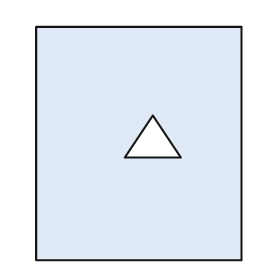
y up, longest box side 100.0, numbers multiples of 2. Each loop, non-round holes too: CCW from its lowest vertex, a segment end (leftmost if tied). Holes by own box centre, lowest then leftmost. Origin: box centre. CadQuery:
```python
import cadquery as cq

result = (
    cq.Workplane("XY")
    .moveTo(-44.0, -50.0)
    .lineTo(44.0, -50.0)
    .lineTo(44.0, 50.0)
    .lineTo(-44.0, 50.0)
    .close()
    .moveTo(-6.0, -6.0)
    .lineTo(18.0, -6.0)
    .lineTo(6.0, 12.0)
    .close()
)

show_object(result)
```